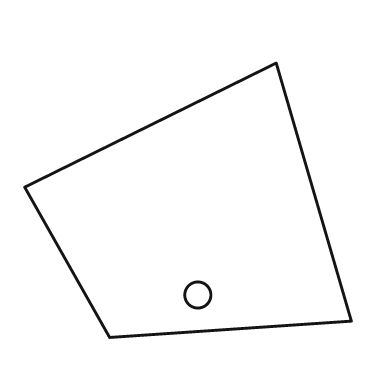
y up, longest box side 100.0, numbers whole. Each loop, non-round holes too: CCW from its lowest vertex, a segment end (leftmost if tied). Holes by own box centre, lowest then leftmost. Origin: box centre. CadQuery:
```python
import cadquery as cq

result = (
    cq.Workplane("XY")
    .moveTo(-24.0, -42.0)
    .lineTo(50.0, -37.0)
    .lineTo(27.0, 42.0)
    .lineTo(-50.0, 4.0)
    .close()
    .moveTo(3.0, -29.0)
    .circle(4.0)
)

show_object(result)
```